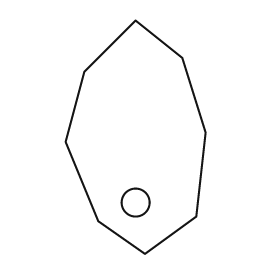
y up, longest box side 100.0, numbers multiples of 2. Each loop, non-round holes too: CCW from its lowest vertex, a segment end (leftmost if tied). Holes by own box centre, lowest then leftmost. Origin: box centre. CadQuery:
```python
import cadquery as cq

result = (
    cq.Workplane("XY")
    .moveTo(4.0, -50.0)
    .lineTo(26.0, -34.0)
    .lineTo(30.0, 2.0)
    .lineTo(20.0, 34.0)
    .lineTo(0.0, 50.0)
    .lineTo(-22.0, 28.0)
    .lineTo(-30.0, -2.0)
    .lineTo(-16.0, -36.0)
    .close()
    .moveTo(0.0, -28.0)
    .circle(6.0)
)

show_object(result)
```